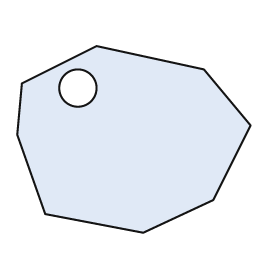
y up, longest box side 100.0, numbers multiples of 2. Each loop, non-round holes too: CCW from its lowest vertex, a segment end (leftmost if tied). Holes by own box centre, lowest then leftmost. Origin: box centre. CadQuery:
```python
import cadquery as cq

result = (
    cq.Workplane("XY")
    .moveTo(4.0, -40.0)
    .lineTo(34.0, -26.0)
    .lineTo(50.0, 6.0)
    .lineTo(30.0, 30.0)
    .lineTo(-16.0, 40.0)
    .lineTo(-48.0, 24.0)
    .lineTo(-50.0, 2.0)
    .lineTo(-38.0, -32.0)
    .close()
    .moveTo(-24.0, 22.0)
    .circle(8.0)
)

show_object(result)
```